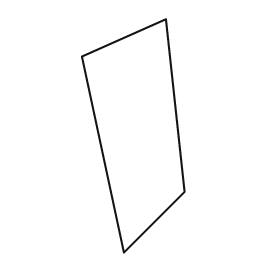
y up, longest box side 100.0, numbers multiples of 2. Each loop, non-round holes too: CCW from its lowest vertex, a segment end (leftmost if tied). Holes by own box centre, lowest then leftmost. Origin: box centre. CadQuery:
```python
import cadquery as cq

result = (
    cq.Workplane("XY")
    .moveTo(-4.0, -50.0)
    .lineTo(22.0, -24.0)
    .lineTo(14.0, 50.0)
    .lineTo(-22.0, 34.0)
    .close()
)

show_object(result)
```